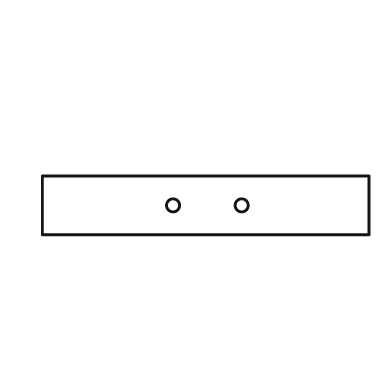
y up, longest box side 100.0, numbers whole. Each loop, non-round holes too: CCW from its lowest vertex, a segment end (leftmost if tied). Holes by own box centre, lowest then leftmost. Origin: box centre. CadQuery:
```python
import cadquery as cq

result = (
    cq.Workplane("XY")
    .moveTo(-50.0, -9.0)
    .lineTo(50.0, -9.0)
    .lineTo(50.0, 9.0)
    .lineTo(-50.0, 9.0)
    .close()
    .moveTo(-10.0, 0.0)
    .circle(2.0)
    .moveTo(11.0, 0.0)
    .circle(2.0)
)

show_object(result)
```